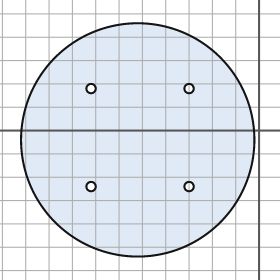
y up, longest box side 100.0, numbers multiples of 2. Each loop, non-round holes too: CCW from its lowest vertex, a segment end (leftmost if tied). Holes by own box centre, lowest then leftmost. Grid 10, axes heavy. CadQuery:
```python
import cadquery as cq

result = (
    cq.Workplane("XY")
    .moveTo(-52.0, -4.0)
    .circle(50.0)
    .moveTo(-72.0, -24.0)
    .circle(2.0)
    .moveTo(-30.0, -24.0)
    .circle(2.0)
    .moveTo(-72.0, 18.0)
    .circle(2.0)
    .moveTo(-30.0, 18.0)
    .circle(2.0)
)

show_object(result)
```